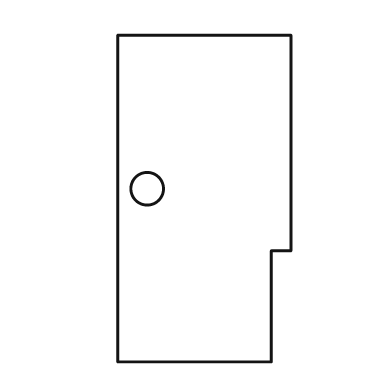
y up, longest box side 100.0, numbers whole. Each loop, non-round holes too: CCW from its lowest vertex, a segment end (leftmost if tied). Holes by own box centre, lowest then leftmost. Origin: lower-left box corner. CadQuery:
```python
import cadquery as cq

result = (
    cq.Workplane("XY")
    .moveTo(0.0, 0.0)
    .lineTo(47.0, 0.0)
    .lineTo(47.0, 34.0)
    .lineTo(53.0, 34.0)
    .lineTo(53.0, 100.0)
    .lineTo(0.0, 100.0)
    .close()
    .moveTo(9.0, 53.0)
    .circle(5.0)
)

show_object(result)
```